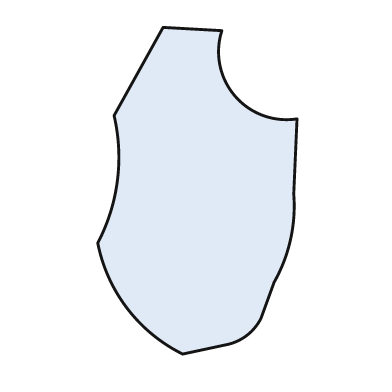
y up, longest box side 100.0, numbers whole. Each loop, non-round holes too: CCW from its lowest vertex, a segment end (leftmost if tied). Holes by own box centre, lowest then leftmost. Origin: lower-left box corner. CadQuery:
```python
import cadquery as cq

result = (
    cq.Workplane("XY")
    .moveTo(26.0, 0.0)
    .lineTo(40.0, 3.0)
    .threePointArc((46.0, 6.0), (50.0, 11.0))
    .lineTo(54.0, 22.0)
    .threePointArc((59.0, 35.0), (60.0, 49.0))
    .lineTo(61.0, 72.0)
    .threePointArc((42.0, 79.0), (38.0, 99.0))
    .lineTo(20.0, 100.0)
    .lineTo(5.0, 73.0)
    .threePointArc((6.0, 53.0), (0.0, 34.0))
    .threePointArc((9.0, 14.0), (26.0, 0.0))
    .close()
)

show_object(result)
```